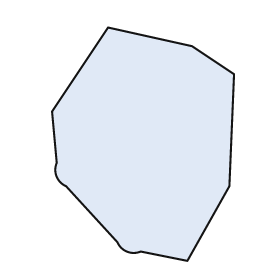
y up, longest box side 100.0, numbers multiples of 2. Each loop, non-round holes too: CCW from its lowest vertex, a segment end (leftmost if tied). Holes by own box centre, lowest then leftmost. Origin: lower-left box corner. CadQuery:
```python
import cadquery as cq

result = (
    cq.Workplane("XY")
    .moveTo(58.0, 0.0)
    .lineTo(76.0, 32.0)
    .lineTo(78.0, 80.0)
    .lineTo(60.0, 92.0)
    .lineTo(24.0, 100.0)
    .lineTo(0.0, 64.0)
    .lineTo(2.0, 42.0)
    .threePointArc((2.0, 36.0), (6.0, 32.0))
    .lineTo(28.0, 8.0)
    .threePointArc((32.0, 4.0), (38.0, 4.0))
    .close()
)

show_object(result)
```